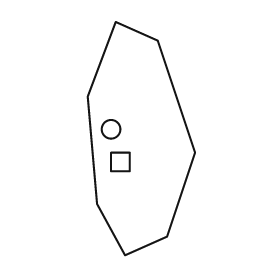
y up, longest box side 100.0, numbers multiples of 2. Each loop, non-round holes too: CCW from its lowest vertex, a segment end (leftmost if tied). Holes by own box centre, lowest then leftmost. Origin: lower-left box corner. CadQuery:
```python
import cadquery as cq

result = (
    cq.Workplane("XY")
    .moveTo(16.0, 0.0)
    .lineTo(34.0, 8.0)
    .lineTo(46.0, 44.0)
    .lineTo(30.0, 92.0)
    .lineTo(12.0, 100.0)
    .lineTo(0.0, 68.0)
    .lineTo(4.0, 22.0)
    .close()
    .moveTo(10.0, 36.0)
    .lineTo(18.0, 36.0)
    .lineTo(18.0, 44.0)
    .lineTo(10.0, 44.0)
    .close()
    .moveTo(10.0, 54.0)
    .circle(4.0)
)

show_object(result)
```